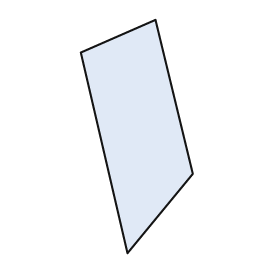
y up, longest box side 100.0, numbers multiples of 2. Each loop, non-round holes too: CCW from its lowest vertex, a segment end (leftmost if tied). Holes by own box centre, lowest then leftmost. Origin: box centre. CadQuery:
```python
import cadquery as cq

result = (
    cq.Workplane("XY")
    .moveTo(-4.0, -50.0)
    .lineTo(24.0, -16.0)
    .lineTo(8.0, 50.0)
    .lineTo(-24.0, 36.0)
    .close()
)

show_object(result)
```